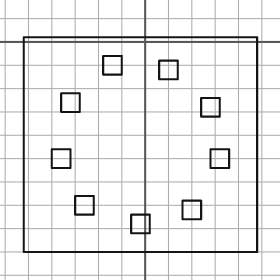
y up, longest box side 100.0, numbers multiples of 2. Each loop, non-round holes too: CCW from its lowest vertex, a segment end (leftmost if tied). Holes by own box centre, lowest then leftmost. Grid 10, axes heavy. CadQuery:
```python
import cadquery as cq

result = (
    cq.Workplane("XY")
    .moveTo(-52.0, -90.0)
    .lineTo(48.0, -90.0)
    .lineTo(48.0, 2.0)
    .lineTo(-52.0, 2.0)
    .close()
    .moveTo(-6.0, -82.0)
    .lineTo(2.0, -82.0)
    .lineTo(2.0, -74.0)
    .lineTo(-6.0, -74.0)
    .close()
    .moveTo(16.0, -76.0)
    .lineTo(24.0, -76.0)
    .lineTo(24.0, -68.0)
    .lineTo(16.0, -68.0)
    .close()
    .moveTo(-30.0, -74.0)
    .lineTo(-22.0, -74.0)
    .lineTo(-22.0, -66.0)
    .lineTo(-30.0, -66.0)
    .close()
    .moveTo(-40.0, -54.0)
    .lineTo(-32.0, -54.0)
    .lineTo(-32.0, -46.0)
    .lineTo(-40.0, -46.0)
    .close()
    .moveTo(28.0, -54.0)
    .lineTo(36.0, -54.0)
    .lineTo(36.0, -46.0)
    .lineTo(28.0, -46.0)
    .close()
    .moveTo(24.0, -32.0)
    .lineTo(32.0, -32.0)
    .lineTo(32.0, -24.0)
    .lineTo(24.0, -24.0)
    .close()
    .moveTo(-36.0, -30.0)
    .lineTo(-28.0, -30.0)
    .lineTo(-28.0, -22.0)
    .lineTo(-36.0, -22.0)
    .close()
    .moveTo(6.0, -16.0)
    .lineTo(14.0, -16.0)
    .lineTo(14.0, -8.0)
    .lineTo(6.0, -8.0)
    .close()
    .moveTo(-18.0, -14.0)
    .lineTo(-10.0, -14.0)
    .lineTo(-10.0, -6.0)
    .lineTo(-18.0, -6.0)
    .close()
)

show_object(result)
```